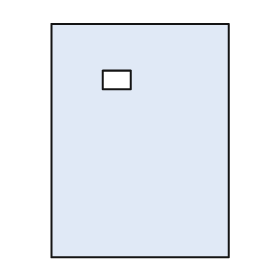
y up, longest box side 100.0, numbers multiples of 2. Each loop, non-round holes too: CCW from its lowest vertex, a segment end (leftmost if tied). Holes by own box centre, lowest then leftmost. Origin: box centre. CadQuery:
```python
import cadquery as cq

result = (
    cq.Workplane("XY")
    .moveTo(-38.0, -50.0)
    .lineTo(38.0, -50.0)
    .lineTo(38.0, 50.0)
    .lineTo(-38.0, 50.0)
    .close()
    .moveTo(-16.0, 22.0)
    .lineTo(-4.0, 22.0)
    .lineTo(-4.0, 30.0)
    .lineTo(-16.0, 30.0)
    .close()
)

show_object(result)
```